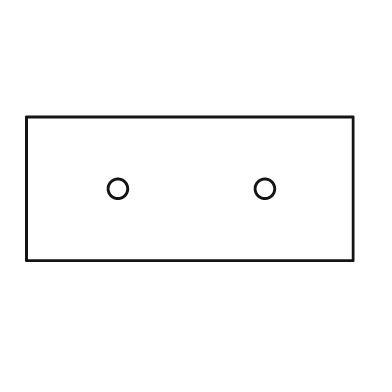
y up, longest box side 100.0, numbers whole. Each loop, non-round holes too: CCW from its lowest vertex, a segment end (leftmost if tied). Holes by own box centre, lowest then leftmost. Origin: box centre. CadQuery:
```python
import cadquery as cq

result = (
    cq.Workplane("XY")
    .moveTo(-50.0, -22.0)
    .lineTo(50.0, -22.0)
    .lineTo(50.0, 22.0)
    .lineTo(-50.0, 22.0)
    .close()
    .moveTo(-22.0, 0.0)
    .circle(3.0)
    .moveTo(23.0, 0.0)
    .circle(3.0)
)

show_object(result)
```